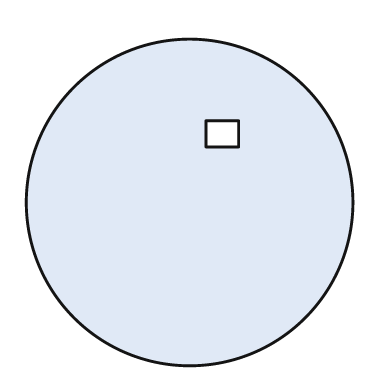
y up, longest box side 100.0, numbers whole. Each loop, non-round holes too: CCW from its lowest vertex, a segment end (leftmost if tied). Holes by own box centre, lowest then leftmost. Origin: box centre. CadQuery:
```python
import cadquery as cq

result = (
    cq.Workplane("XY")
    .moveTo(0.0, 0.0)
    .circle(50.0)
    .moveTo(5.0, 17.0)
    .lineTo(15.0, 17.0)
    .lineTo(15.0, 25.0)
    .lineTo(5.0, 25.0)
    .close()
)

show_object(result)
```